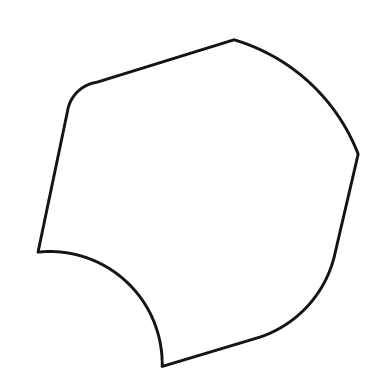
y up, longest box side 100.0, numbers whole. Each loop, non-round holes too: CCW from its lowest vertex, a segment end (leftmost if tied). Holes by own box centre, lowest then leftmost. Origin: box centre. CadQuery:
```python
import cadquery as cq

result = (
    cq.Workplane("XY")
    .moveTo(-11.0, -50.0)
    .lineTo(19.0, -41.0)
    .threePointArc((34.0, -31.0), (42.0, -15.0))
    .lineTo(49.0, 15.0)
    .threePointArc((34.0, 37.0), (11.0, 50.0))
    .lineTo(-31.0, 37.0)
    .threePointArc((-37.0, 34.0), (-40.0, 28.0))
    .lineTo(-49.0, -15.0)
    .threePointArc((-22.0, -24.0), (-11.0, -50.0))
    .close()
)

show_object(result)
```